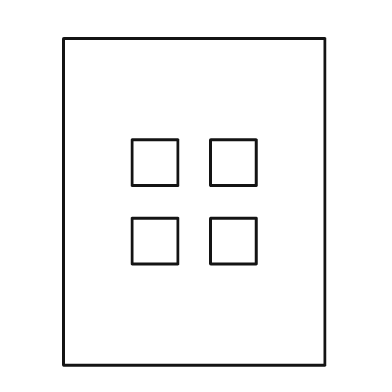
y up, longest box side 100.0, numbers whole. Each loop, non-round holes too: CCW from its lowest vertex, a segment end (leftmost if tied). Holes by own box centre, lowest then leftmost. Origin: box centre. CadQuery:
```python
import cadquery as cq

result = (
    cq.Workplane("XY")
    .moveTo(-40.0, -50.0)
    .lineTo(40.0, -50.0)
    .lineTo(40.0, 50.0)
    .lineTo(-40.0, 50.0)
    .close()
    .moveTo(-19.0, -19.0)
    .lineTo(-5.0, -19.0)
    .lineTo(-5.0, -5.0)
    .lineTo(-19.0, -5.0)
    .close()
    .moveTo(5.0, -19.0)
    .lineTo(19.0, -19.0)
    .lineTo(19.0, -5.0)
    .lineTo(5.0, -5.0)
    .close()
    .moveTo(-19.0, 5.0)
    .lineTo(-5.0, 5.0)
    .lineTo(-5.0, 19.0)
    .lineTo(-19.0, 19.0)
    .close()
    .moveTo(5.0, 5.0)
    .lineTo(19.0, 5.0)
    .lineTo(19.0, 19.0)
    .lineTo(5.0, 19.0)
    .close()
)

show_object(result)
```